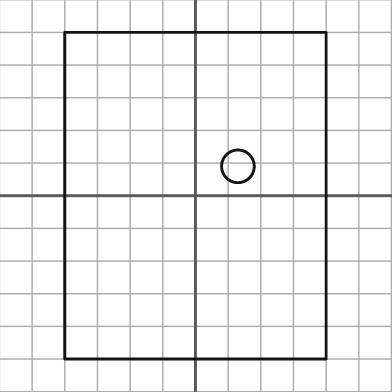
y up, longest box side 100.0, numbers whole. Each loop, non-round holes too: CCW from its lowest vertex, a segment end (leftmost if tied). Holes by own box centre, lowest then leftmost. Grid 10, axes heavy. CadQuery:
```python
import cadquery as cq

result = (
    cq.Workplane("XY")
    .moveTo(-40.0, -50.0)
    .lineTo(40.0, -50.0)
    .lineTo(40.0, 50.0)
    .lineTo(-40.0, 50.0)
    .close()
    .moveTo(13.0, 9.0)
    .circle(5.0)
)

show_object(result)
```